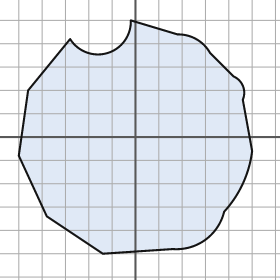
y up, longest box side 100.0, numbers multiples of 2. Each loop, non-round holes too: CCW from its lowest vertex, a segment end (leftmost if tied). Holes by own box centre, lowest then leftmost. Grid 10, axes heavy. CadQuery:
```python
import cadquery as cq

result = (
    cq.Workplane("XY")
    .moveTo(-14.0, -50.0)
    .lineTo(16.0, -48.0)
    .threePointArc((30.0, -44.0), (38.0, -32.0))
    .threePointArc((46.0, -20.0), (50.0, -6.0))
    .lineTo(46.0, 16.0)
    .threePointArc((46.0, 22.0), (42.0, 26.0))
    .lineTo(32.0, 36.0)
    .threePointArc((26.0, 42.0), (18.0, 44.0))
    .lineTo(-2.0, 50.0)
    .threePointArc((-12.0, 36.0), (-28.0, 42.0))
    .lineTo(-46.0, 20.0)
    .lineTo(-50.0, -8.0)
    .lineTo(-38.0, -34.0)
    .close()
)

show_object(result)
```